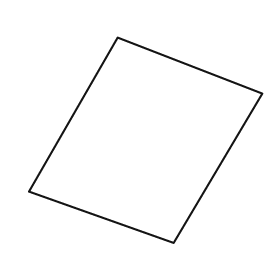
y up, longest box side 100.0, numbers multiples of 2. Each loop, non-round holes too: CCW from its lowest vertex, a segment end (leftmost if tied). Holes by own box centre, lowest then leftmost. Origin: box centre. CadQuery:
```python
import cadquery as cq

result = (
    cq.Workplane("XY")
    .moveTo(12.0, -44.0)
    .lineTo(50.0, 20.0)
    .lineTo(-12.0, 44.0)
    .lineTo(-50.0, -22.0)
    .close()
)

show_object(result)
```